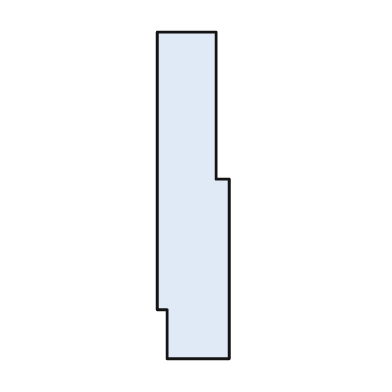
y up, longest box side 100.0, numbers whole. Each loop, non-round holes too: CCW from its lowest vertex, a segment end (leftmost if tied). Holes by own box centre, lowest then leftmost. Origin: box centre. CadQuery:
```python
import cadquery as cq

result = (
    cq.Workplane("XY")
    .moveTo(-8.0, -50.0)
    .lineTo(11.0, -50.0)
    .lineTo(11.0, 5.0)
    .lineTo(7.0, 5.0)
    .lineTo(7.0, 50.0)
    .lineTo(-11.0, 50.0)
    .lineTo(-11.0, -35.0)
    .lineTo(-8.0, -35.0)
    .close()
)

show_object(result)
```